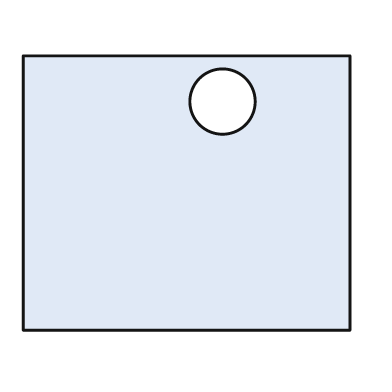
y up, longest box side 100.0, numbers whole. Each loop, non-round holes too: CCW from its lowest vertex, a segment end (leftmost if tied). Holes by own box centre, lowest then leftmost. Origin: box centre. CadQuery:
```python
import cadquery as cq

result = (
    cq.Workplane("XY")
    .moveTo(-50.0, -42.0)
    .lineTo(50.0, -42.0)
    .lineTo(50.0, 42.0)
    .lineTo(-50.0, 42.0)
    .close()
    .moveTo(11.0, 28.0)
    .circle(10.0)
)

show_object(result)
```